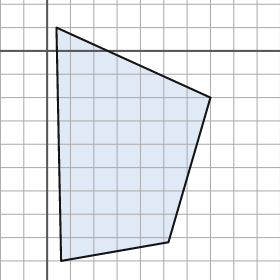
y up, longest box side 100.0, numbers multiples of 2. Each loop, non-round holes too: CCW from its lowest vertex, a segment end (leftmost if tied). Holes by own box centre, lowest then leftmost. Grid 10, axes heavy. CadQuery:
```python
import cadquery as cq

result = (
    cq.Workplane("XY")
    .moveTo(6.0, -90.0)
    .lineTo(52.0, -82.0)
    .lineTo(70.0, -20.0)
    .lineTo(4.0, 10.0)
    .close()
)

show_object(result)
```